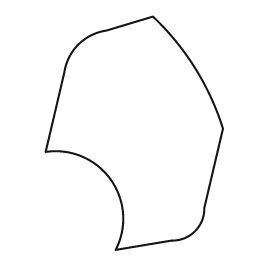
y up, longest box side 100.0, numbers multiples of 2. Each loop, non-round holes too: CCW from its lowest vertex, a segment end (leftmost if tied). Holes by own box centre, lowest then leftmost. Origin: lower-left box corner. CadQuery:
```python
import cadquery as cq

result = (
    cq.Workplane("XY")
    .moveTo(30.0, 0.0)
    .lineTo(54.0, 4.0)
    .threePointArc((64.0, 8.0), (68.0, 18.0))
    .lineTo(76.0, 52.0)
    .threePointArc((64.0, 78.0), (46.0, 100.0))
    .lineTo(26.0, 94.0)
    .threePointArc((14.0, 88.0), (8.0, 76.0))
    .lineTo(0.0, 42.0)
    .threePointArc((28.0, 30.0), (30.0, 0.0))
    .close()
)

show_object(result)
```